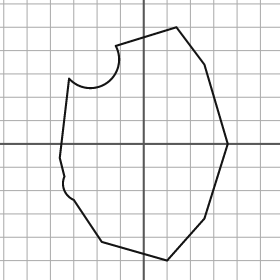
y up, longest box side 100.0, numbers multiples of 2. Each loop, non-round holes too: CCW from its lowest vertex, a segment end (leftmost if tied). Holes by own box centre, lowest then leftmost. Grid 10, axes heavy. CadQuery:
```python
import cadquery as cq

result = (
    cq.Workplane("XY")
    .moveTo(10.0, -50.0)
    .lineTo(26.0, -32.0)
    .lineTo(36.0, 0.0)
    .lineTo(26.0, 34.0)
    .lineTo(14.0, 50.0)
    .lineTo(-12.0, 42.0)
    .threePointArc((-16.0, 26.0), (-32.0, 28.0))
    .lineTo(-36.0, -6.0)
    .lineTo(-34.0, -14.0)
    .threePointArc((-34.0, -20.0), (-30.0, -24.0))
    .lineTo(-18.0, -42.0)
    .close()
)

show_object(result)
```